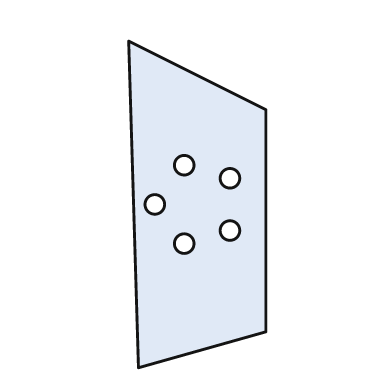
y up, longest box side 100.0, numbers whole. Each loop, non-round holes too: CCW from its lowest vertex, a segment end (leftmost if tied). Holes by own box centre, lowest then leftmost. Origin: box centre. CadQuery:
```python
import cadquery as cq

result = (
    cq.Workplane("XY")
    .moveTo(-18.0, -50.0)
    .lineTo(21.0, -39.0)
    .lineTo(21.0, 29.0)
    .lineTo(-21.0, 50.0)
    .close()
    .moveTo(-4.0, -12.0)
    .circle(3.0)
    .moveTo(10.0, -8.0)
    .circle(3.0)
    .moveTo(-13.0, 0.0)
    .circle(3.0)
    .moveTo(10.0, 8.0)
    .circle(3.0)
    .moveTo(-4.0, 12.0)
    .circle(3.0)
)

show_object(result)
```